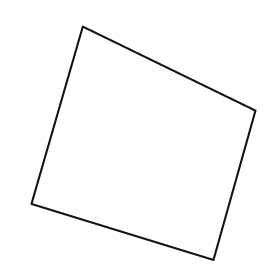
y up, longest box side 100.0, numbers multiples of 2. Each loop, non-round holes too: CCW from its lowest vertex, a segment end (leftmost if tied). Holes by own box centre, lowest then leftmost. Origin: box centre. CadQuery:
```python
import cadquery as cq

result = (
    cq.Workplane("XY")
    .moveTo(30.0, -50.0)
    .lineTo(48.0, 14.0)
    .lineTo(-26.0, 50.0)
    .lineTo(-48.0, -26.0)
    .close()
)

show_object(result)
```